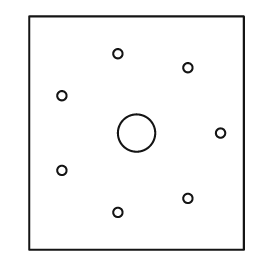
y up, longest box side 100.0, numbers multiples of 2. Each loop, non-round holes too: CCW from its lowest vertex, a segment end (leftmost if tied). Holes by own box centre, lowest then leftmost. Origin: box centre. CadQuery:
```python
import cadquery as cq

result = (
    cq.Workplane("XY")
    .moveTo(-46.0, -50.0)
    .lineTo(46.0, -50.0)
    .lineTo(46.0, 50.0)
    .lineTo(-46.0, 50.0)
    .close()
    .moveTo(-8.0, -34.0)
    .circle(2.0)
    .moveTo(22.0, -28.0)
    .circle(2.0)
    .moveTo(-32.0, -16.0)
    .circle(2.0)
    .moveTo(0.0, 0.0)
    .circle(8.0)
    .moveTo(36.0, 0.0)
    .circle(2.0)
    .moveTo(-32.0, 16.0)
    .circle(2.0)
    .moveTo(22.0, 28.0)
    .circle(2.0)
    .moveTo(-8.0, 34.0)
    .circle(2.0)
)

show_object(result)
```